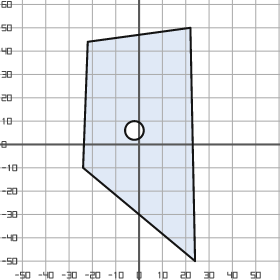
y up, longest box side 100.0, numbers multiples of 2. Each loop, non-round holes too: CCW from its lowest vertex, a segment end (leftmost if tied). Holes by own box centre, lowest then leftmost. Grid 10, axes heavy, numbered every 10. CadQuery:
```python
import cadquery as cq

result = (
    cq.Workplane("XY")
    .moveTo(24.0, -50.0)
    .lineTo(22.0, 50.0)
    .lineTo(-22.0, 44.0)
    .lineTo(-24.0, -10.0)
    .close()
    .moveTo(-2.0, 6.0)
    .circle(4.0)
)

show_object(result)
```